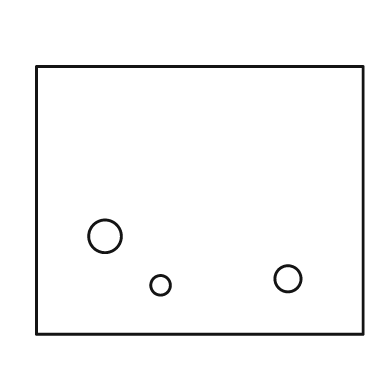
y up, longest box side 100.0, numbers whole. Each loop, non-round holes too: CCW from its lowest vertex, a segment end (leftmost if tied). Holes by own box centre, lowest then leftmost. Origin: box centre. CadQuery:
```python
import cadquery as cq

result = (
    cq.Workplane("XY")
    .moveTo(-50.0, -41.0)
    .lineTo(50.0, -41.0)
    .lineTo(50.0, 41.0)
    .lineTo(-50.0, 41.0)
    .close()
    .moveTo(-12.0, -26.0)
    .circle(3.0)
    .moveTo(27.0, -24.0)
    .circle(4.0)
    .moveTo(-29.0, -11.0)
    .circle(5.0)
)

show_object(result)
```